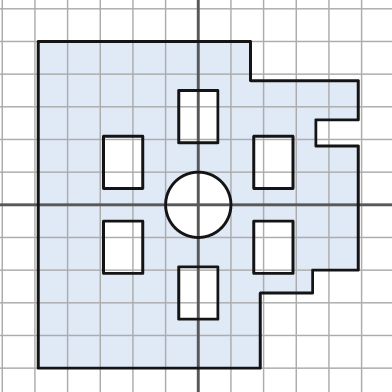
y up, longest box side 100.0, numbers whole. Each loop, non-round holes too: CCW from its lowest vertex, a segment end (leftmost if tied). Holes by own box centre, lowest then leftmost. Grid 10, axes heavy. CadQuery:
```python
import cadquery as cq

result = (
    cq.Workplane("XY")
    .moveTo(-49.0, -50.0)
    .lineTo(19.0, -50.0)
    .lineTo(19.0, -27.0)
    .lineTo(35.0, -27.0)
    .lineTo(35.0, -20.0)
    .lineTo(49.0, -20.0)
    .lineTo(49.0, 18.0)
    .lineTo(36.0, 18.0)
    .lineTo(36.0, 26.0)
    .lineTo(49.0, 26.0)
    .lineTo(49.0, 38.0)
    .lineTo(16.0, 38.0)
    .lineTo(16.0, 50.0)
    .lineTo(-49.0, 50.0)
    .close()
    .moveTo(-6.0, -35.0)
    .lineTo(6.0, -35.0)
    .lineTo(6.0, -19.0)
    .lineTo(-6.0, -19.0)
    .close()
    .moveTo(-29.0, -21.0)
    .lineTo(-17.0, -21.0)
    .lineTo(-17.0, -5.0)
    .lineTo(-29.0, -5.0)
    .close()
    .moveTo(17.0, -21.0)
    .lineTo(29.0, -21.0)
    .lineTo(29.0, -5.0)
    .lineTo(17.0, -5.0)
    .close()
    .moveTo(0.0, 0.0)
    .circle(10.0)
    .moveTo(-29.0, 5.0)
    .lineTo(-17.0, 5.0)
    .lineTo(-17.0, 21.0)
    .lineTo(-29.0, 21.0)
    .close()
    .moveTo(17.0, 5.0)
    .lineTo(29.0, 5.0)
    .lineTo(29.0, 21.0)
    .lineTo(17.0, 21.0)
    .close()
    .moveTo(-6.0, 19.0)
    .lineTo(6.0, 19.0)
    .lineTo(6.0, 35.0)
    .lineTo(-6.0, 35.0)
    .close()
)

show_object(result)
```